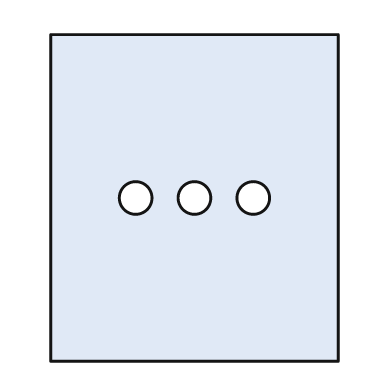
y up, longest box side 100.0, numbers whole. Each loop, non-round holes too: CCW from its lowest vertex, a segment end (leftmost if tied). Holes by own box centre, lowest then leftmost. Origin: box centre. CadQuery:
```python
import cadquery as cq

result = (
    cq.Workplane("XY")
    .moveTo(-44.0, -50.0)
    .lineTo(44.0, -50.0)
    .lineTo(44.0, 50.0)
    .lineTo(-44.0, 50.0)
    .close()
    .moveTo(-18.0, 0.0)
    .circle(5.0)
    .moveTo(0.0, 0.0)
    .circle(5.0)
    .moveTo(18.0, 0.0)
    .circle(5.0)
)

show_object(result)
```